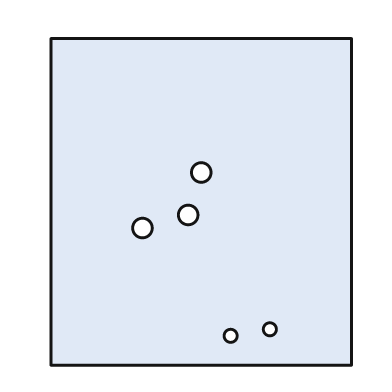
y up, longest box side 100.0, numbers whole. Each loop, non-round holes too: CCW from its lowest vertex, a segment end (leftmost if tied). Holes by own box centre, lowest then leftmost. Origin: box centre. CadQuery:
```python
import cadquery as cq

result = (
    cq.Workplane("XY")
    .moveTo(-46.0, -50.0)
    .lineTo(46.0, -50.0)
    .lineTo(46.0, 50.0)
    .lineTo(-46.0, 50.0)
    .close()
    .moveTo(9.0, -41.0)
    .circle(2.0)
    .moveTo(21.0, -39.0)
    .circle(2.0)
    .moveTo(-18.0, -8.0)
    .circle(3.0)
    .moveTo(-4.0, -4.0)
    .circle(3.0)
    .moveTo(0.0, 9.0)
    .circle(3.0)
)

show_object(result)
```